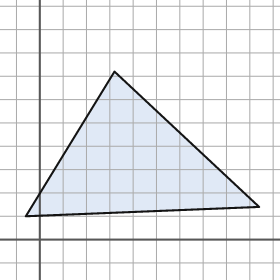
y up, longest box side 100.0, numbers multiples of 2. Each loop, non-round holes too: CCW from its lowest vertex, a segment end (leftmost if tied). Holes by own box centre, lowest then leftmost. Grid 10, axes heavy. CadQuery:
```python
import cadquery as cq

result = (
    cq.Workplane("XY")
    .moveTo(-6.0, 10.0)
    .lineTo(94.0, 14.0)
    .lineTo(32.0, 72.0)
    .close()
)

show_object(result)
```